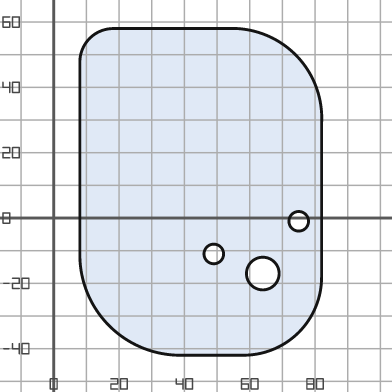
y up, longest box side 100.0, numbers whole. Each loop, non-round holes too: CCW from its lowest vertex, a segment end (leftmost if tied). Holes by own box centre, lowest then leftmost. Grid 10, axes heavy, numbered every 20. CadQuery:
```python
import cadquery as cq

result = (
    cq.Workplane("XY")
    .moveTo(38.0, -42.0)
    .lineTo(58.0, -42.0)
    .threePointArc((75.0, -35.0), (82.0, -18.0))
    .lineTo(82.0, 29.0)
    .threePointArc((74.0, 50.0), (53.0, 58.0))
    .lineTo(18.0, 58.0)
    .threePointArc((11.0, 55.0), (8.0, 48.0))
    .lineTo(8.0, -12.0)
    .threePointArc((17.0, -33.0), (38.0, -42.0))
    .close()
    .moveTo(64.0, -17.0)
    .circle(5.0)
    .moveTo(49.0, -11.0)
    .circle(3.0)
    .moveTo(75.0, -1.0)
    .circle(3.0)
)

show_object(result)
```